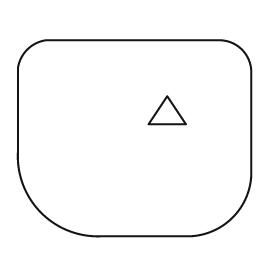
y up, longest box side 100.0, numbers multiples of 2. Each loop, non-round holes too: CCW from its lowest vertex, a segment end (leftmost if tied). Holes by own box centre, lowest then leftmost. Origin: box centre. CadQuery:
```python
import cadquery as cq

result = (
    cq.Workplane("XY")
    .moveTo(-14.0, -42.0)
    .lineTo(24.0, -42.0)
    .threePointArc((42.0, -34.0), (50.0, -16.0))
    .lineTo(50.0, 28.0)
    .threePointArc((46.0, 38.0), (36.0, 42.0))
    .lineTo(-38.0, 42.0)
    .threePointArc((-46.0, 38.0), (-50.0, 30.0))
    .lineTo(-50.0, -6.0)
    .threePointArc((-40.0, -32.0), (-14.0, -42.0))
    .close()
    .moveTo(6.0, 6.0)
    .lineTo(22.0, 6.0)
    .lineTo(14.0, 18.0)
    .close()
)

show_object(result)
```